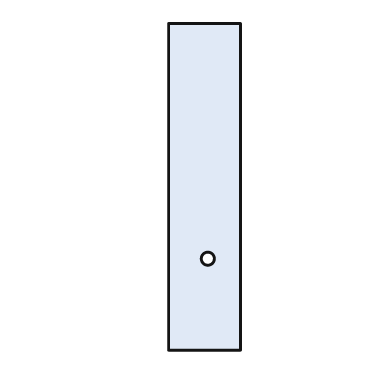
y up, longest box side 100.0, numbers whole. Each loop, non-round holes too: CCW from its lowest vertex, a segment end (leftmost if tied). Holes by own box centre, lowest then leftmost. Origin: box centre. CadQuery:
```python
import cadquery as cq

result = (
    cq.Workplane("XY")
    .moveTo(-11.0, -50.0)
    .lineTo(11.0, -50.0)
    .lineTo(11.0, 50.0)
    .lineTo(-11.0, 50.0)
    .close()
    .moveTo(1.0, -22.0)
    .circle(2.0)
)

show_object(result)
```